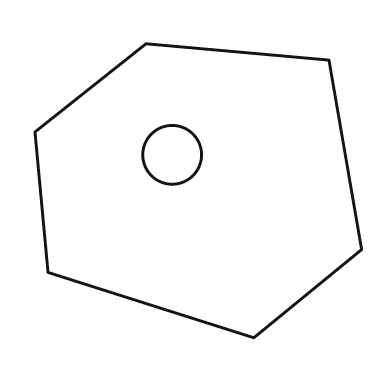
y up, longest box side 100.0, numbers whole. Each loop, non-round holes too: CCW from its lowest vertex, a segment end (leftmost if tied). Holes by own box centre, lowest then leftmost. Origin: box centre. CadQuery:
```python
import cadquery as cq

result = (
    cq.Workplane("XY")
    .moveTo(17.0, -45.0)
    .lineTo(50.0, -18.0)
    .lineTo(40.0, 40.0)
    .lineTo(-16.0, 45.0)
    .lineTo(-50.0, 18.0)
    .lineTo(-46.0, -25.0)
    .close()
    .moveTo(-8.0, 11.0)
    .circle(9.0)
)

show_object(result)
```